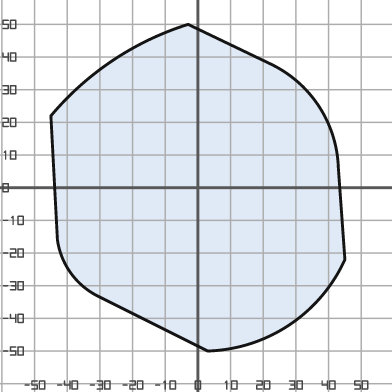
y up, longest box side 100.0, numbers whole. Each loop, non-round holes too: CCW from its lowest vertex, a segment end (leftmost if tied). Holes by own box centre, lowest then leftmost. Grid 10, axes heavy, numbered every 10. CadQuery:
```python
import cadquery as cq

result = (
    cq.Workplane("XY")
    .moveTo(3.0, -50.0)
    .threePointArc((28.0, -42.0), (45.0, -22.0))
    .lineTo(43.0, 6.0)
    .threePointArc((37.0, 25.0), (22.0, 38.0))
    .lineTo(-3.0, 50.0)
    .threePointArc((-26.0, 39.0), (-45.0, 22.0))
    .lineTo(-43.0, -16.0)
    .threePointArc((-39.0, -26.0), (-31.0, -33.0))
    .close()
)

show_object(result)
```